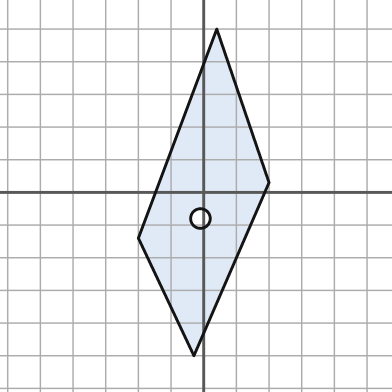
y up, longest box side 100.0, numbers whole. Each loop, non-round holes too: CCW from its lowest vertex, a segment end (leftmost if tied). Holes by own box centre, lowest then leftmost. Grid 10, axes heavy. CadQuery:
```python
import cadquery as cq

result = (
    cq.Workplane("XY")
    .moveTo(-3.0, -50.0)
    .lineTo(20.0, 3.0)
    .lineTo(4.0, 50.0)
    .lineTo(-20.0, -14.0)
    .close()
    .moveTo(-1.0, -8.0)
    .circle(3.0)
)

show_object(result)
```